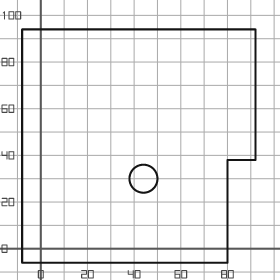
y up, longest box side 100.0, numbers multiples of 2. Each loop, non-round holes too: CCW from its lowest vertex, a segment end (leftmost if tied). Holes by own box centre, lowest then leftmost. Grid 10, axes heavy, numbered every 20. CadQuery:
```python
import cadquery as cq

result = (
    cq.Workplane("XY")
    .moveTo(-8.0, -6.0)
    .lineTo(80.0, -6.0)
    .lineTo(80.0, 38.0)
    .lineTo(92.0, 38.0)
    .lineTo(92.0, 94.0)
    .lineTo(-8.0, 94.0)
    .close()
    .moveTo(44.0, 30.0)
    .circle(6.0)
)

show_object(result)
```